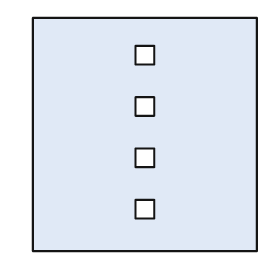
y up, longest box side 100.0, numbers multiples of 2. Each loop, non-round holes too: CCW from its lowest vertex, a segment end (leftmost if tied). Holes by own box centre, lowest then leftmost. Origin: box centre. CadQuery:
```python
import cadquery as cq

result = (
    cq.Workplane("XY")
    .moveTo(-48.0, -50.0)
    .lineTo(48.0, -50.0)
    .lineTo(48.0, 50.0)
    .lineTo(-48.0, 50.0)
    .close()
    .moveTo(-4.0, -36.0)
    .lineTo(4.0, -36.0)
    .lineTo(4.0, -28.0)
    .lineTo(-4.0, -28.0)
    .close()
    .moveTo(-4.0, -14.0)
    .lineTo(4.0, -14.0)
    .lineTo(4.0, -6.0)
    .lineTo(-4.0, -6.0)
    .close()
    .moveTo(-4.0, 8.0)
    .lineTo(4.0, 8.0)
    .lineTo(4.0, 16.0)
    .lineTo(-4.0, 16.0)
    .close()
    .moveTo(-4.0, 30.0)
    .lineTo(4.0, 30.0)
    .lineTo(4.0, 38.0)
    .lineTo(-4.0, 38.0)
    .close()
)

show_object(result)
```